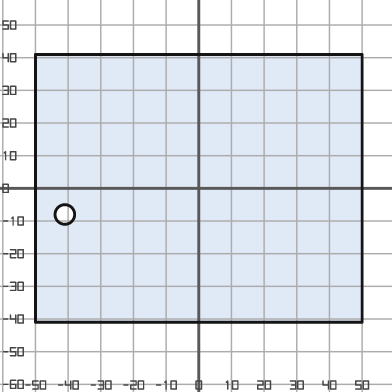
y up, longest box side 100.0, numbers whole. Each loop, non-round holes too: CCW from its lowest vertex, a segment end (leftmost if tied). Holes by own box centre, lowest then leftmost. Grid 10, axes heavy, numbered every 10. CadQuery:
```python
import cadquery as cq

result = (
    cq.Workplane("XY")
    .moveTo(-50.0, -41.0)
    .lineTo(50.0, -41.0)
    .lineTo(50.0, 41.0)
    .lineTo(-50.0, 41.0)
    .close()
    .moveTo(-41.0, -8.0)
    .circle(3.0)
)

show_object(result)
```